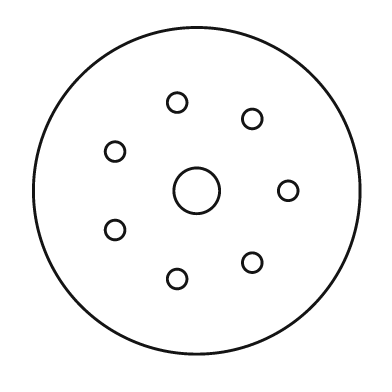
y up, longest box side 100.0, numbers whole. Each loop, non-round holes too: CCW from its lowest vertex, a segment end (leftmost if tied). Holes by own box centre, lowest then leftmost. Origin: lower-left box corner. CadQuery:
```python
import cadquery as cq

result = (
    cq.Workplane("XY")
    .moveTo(50.0, 50.0)
    .circle(50.0)
    .moveTo(44.0, 23.0)
    .circle(3.0)
    .moveTo(67.0, 28.0)
    .circle(3.0)
    .moveTo(25.0, 38.0)
    .circle(3.0)
    .moveTo(50.0, 50.0)
    .circle(7.0)
    .moveTo(78.0, 50.0)
    .circle(3.0)
    .moveTo(25.0, 62.0)
    .circle(3.0)
    .moveTo(67.0, 72.0)
    .circle(3.0)
    .moveTo(44.0, 77.0)
    .circle(3.0)
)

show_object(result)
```